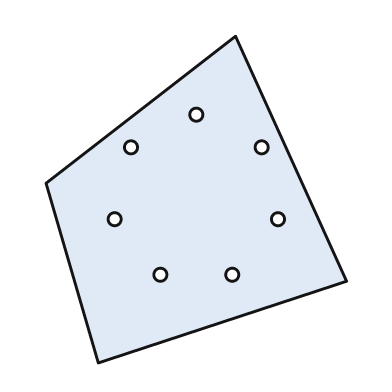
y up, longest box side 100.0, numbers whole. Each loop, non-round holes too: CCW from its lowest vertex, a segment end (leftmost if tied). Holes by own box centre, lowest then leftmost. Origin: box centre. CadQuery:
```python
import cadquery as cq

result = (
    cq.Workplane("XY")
    .moveTo(-30.0, -50.0)
    .lineTo(46.0, -25.0)
    .lineTo(12.0, 50.0)
    .lineTo(-46.0, 5.0)
    .close()
    .moveTo(-11.0, -23.0)
    .circle(2.0)
    .moveTo(11.0, -23.0)
    .circle(2.0)
    .moveTo(-25.0, -6.0)
    .circle(2.0)
    .moveTo(25.0, -6.0)
    .circle(2.0)
    .moveTo(-20.0, 16.0)
    .circle(2.0)
    .moveTo(20.0, 16.0)
    .circle(2.0)
    .moveTo(0.0, 26.0)
    .circle(2.0)
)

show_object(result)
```